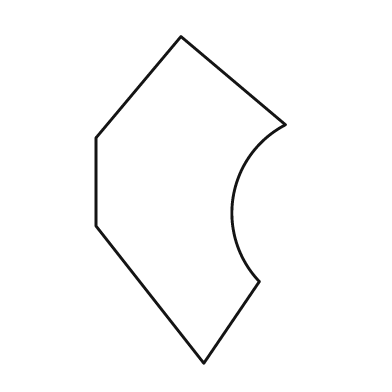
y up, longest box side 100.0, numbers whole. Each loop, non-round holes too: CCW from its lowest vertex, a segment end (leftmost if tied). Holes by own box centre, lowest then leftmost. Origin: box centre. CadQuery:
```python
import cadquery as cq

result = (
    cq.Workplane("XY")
    .moveTo(4.0, -50.0)
    .lineTo(21.0, -25.0)
    .threePointArc((13.0, 1.0), (29.0, 23.0))
    .lineTo(-3.0, 50.0)
    .lineTo(-29.0, 19.0)
    .lineTo(-29.0, -8.0)
    .close()
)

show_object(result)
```